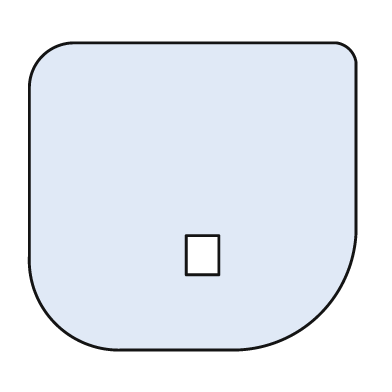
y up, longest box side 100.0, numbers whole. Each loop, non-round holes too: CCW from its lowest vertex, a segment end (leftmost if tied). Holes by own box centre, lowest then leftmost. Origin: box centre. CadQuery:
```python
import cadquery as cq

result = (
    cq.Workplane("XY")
    .moveTo(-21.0, -47.0)
    .lineTo(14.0, -47.0)
    .threePointArc((39.0, -36.0), (50.0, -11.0))
    .lineTo(50.0, 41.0)
    .threePointArc((48.0, 45.0), (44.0, 47.0))
    .lineTo(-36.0, 47.0)
    .threePointArc((-46.0, 43.0), (-50.0, 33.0))
    .lineTo(-50.0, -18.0)
    .threePointArc((-42.0, -39.0), (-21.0, -47.0))
    .close()
    .moveTo(-2.0, -24.0)
    .lineTo(8.0, -24.0)
    .lineTo(8.0, -12.0)
    .lineTo(-2.0, -12.0)
    .close()
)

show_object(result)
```